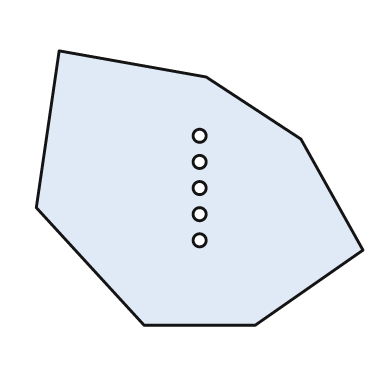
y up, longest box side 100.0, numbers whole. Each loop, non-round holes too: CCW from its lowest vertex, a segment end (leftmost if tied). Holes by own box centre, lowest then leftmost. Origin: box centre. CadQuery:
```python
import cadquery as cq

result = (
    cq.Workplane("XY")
    .moveTo(-17.0, -42.0)
    .lineTo(17.0, -42.0)
    .lineTo(50.0, -19.0)
    .lineTo(31.0, 15.0)
    .lineTo(2.0, 34.0)
    .lineTo(-43.0, 42.0)
    .lineTo(-50.0, -6.0)
    .close()
    .moveTo(0.0, -16.0)
    .circle(2.0)
    .moveTo(0.0, -8.0)
    .circle(2.0)
    .moveTo(0.0, 0.0)
    .circle(2.0)
    .moveTo(0.0, 8.0)
    .circle(2.0)
    .moveTo(0.0, 16.0)
    .circle(2.0)
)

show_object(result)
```